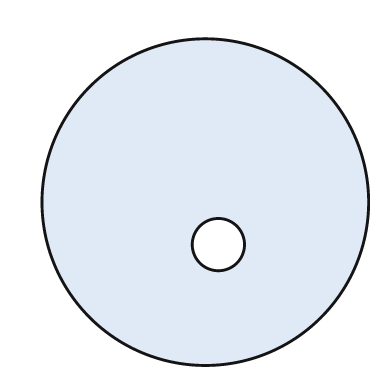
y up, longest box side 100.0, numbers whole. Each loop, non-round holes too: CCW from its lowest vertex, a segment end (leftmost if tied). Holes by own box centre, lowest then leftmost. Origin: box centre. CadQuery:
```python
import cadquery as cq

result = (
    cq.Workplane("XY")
    .moveTo(0.0, 0.0)
    .circle(50.0)
    .moveTo(4.0, -13.0)
    .circle(8.0)
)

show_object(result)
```